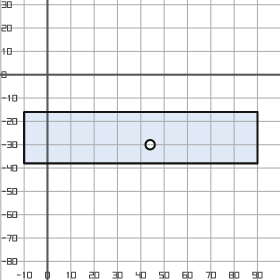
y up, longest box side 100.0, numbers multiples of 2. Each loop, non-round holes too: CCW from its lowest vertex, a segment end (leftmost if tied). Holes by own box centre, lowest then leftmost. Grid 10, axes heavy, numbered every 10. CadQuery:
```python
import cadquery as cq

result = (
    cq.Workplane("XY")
    .moveTo(-10.0, -38.0)
    .lineTo(90.0, -38.0)
    .lineTo(90.0, -16.0)
    .lineTo(-10.0, -16.0)
    .close()
    .moveTo(44.0, -30.0)
    .circle(2.0)
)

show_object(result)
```